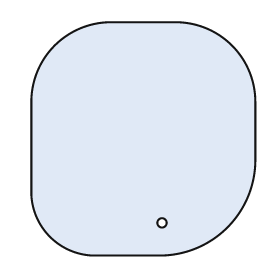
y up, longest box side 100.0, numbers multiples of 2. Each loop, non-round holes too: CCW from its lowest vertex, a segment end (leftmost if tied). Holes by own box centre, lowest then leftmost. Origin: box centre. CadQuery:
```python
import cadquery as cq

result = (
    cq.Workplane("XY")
    .moveTo(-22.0, -50.0)
    .lineTo(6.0, -50.0)
    .threePointArc((36.0, -38.0), (48.0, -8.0))
    .lineTo(48.0, 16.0)
    .threePointArc((38.0, 40.0), (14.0, 50.0))
    .lineTo(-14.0, 50.0)
    .threePointArc((-38.0, 40.0), (-48.0, 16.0))
    .lineTo(-48.0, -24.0)
    .threePointArc((-40.0, -42.0), (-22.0, -50.0))
    .close()
    .moveTo(8.0, -36.0)
    .circle(2.0)
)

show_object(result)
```